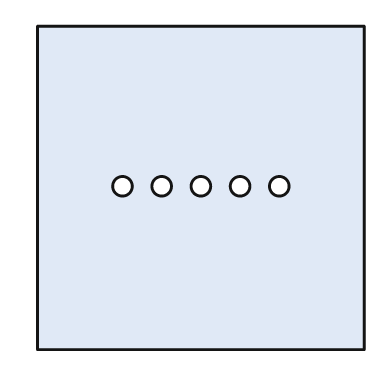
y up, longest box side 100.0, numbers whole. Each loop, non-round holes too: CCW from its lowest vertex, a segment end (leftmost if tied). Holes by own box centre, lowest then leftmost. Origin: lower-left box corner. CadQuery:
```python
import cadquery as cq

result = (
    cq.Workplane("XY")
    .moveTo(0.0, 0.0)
    .lineTo(100.0, 0.0)
    .lineTo(100.0, 99.0)
    .lineTo(0.0, 99.0)
    .close()
    .moveTo(26.0, 50.0)
    .circle(3.0)
    .moveTo(38.0, 50.0)
    .circle(3.0)
    .moveTo(50.0, 50.0)
    .circle(3.0)
    .moveTo(62.0, 50.0)
    .circle(3.0)
    .moveTo(74.0, 50.0)
    .circle(3.0)
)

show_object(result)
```